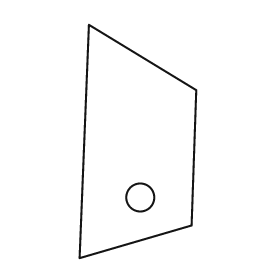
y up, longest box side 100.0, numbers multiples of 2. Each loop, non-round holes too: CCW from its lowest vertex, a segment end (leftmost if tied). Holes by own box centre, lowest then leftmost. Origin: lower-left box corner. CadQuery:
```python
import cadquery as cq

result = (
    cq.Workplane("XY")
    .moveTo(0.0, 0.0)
    .lineTo(48.0, 14.0)
    .lineTo(50.0, 72.0)
    .lineTo(4.0, 100.0)
    .close()
    .moveTo(26.0, 26.0)
    .circle(6.0)
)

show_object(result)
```